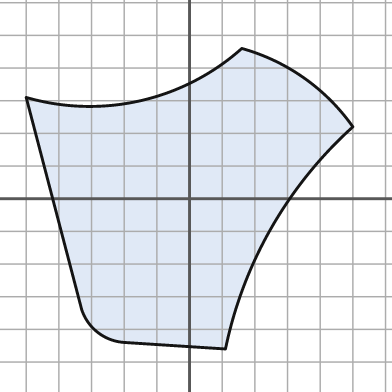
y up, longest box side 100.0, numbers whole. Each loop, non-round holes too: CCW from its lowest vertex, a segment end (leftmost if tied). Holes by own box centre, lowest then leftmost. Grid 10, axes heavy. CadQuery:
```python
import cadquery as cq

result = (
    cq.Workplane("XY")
    .moveTo(11.0, -46.0)
    .threePointArc((25.0, -9.0), (50.0, 22.0))
    .threePointArc((35.0, 37.0), (16.0, 46.0))
    .threePointArc((-15.0, 30.0), (-50.0, 31.0))
    .lineTo(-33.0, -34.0)
    .threePointArc((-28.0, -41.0), (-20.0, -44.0))
    .close()
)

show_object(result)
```